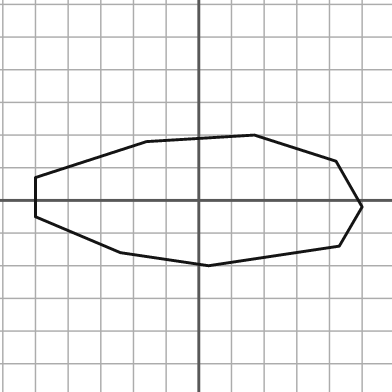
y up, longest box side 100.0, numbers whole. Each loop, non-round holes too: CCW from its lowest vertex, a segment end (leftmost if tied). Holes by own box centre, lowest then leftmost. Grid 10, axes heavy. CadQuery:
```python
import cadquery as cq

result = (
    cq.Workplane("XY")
    .moveTo(3.0, -20.0)
    .lineTo(43.0, -14.0)
    .lineTo(50.0, -2.0)
    .lineTo(42.0, 12.0)
    .lineTo(17.0, 20.0)
    .lineTo(-16.0, 18.0)
    .lineTo(-50.0, 7.0)
    .lineTo(-50.0, -5.0)
    .lineTo(-24.0, -16.0)
    .close()
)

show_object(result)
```